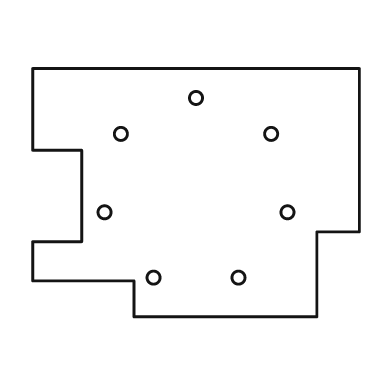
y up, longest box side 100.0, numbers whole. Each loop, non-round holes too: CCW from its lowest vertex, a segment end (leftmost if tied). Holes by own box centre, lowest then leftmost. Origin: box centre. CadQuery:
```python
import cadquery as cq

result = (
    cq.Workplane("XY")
    .moveTo(-19.0, -38.0)
    .lineTo(37.0, -38.0)
    .lineTo(37.0, -12.0)
    .lineTo(50.0, -12.0)
    .lineTo(50.0, 38.0)
    .lineTo(-50.0, 38.0)
    .lineTo(-50.0, 13.0)
    .lineTo(-35.0, 13.0)
    .lineTo(-35.0, -15.0)
    .lineTo(-50.0, -15.0)
    .lineTo(-50.0, -27.0)
    .lineTo(-19.0, -27.0)
    .close()
    .moveTo(-13.0, -26.0)
    .circle(2.0)
    .moveTo(13.0, -26.0)
    .circle(2.0)
    .moveTo(-28.0, -6.0)
    .circle(2.0)
    .moveTo(28.0, -6.0)
    .circle(2.0)
    .moveTo(-23.0, 18.0)
    .circle(2.0)
    .moveTo(23.0, 18.0)
    .circle(2.0)
    .moveTo(0.0, 29.0)
    .circle(2.0)
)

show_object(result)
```